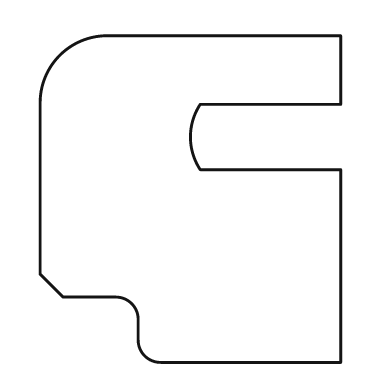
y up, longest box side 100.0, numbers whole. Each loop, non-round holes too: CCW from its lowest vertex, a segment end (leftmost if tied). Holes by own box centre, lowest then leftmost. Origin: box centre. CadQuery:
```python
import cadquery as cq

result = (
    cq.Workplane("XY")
    .moveTo(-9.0, -50.0)
    .lineTo(46.0, -50.0)
    .lineTo(46.0, 9.0)
    .lineTo(3.0, 9.0)
    .threePointArc((0.0, 19.0), (3.0, 29.0))
    .lineTo(46.0, 29.0)
    .lineTo(46.0, 50.0)
    .lineTo(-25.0, 50.0)
    .threePointArc((-40.0, 44.0), (-46.0, 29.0))
    .lineTo(-46.0, -23.0)
    .lineTo(-39.0, -30.0)
    .lineTo(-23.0, -30.0)
    .threePointArc((-18.0, -32.0), (-16.0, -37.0))
    .lineTo(-16.0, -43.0)
    .threePointArc((-14.0, -48.0), (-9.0, -50.0))
    .close()
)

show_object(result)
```